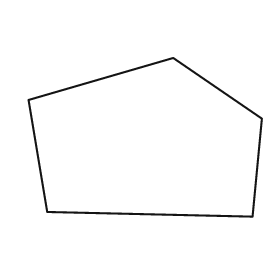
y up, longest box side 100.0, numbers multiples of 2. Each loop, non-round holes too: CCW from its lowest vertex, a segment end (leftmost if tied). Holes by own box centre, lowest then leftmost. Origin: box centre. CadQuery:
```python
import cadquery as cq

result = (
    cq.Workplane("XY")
    .moveTo(46.0, -34.0)
    .lineTo(50.0, 8.0)
    .lineTo(12.0, 34.0)
    .lineTo(-50.0, 16.0)
    .lineTo(-42.0, -32.0)
    .close()
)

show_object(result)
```